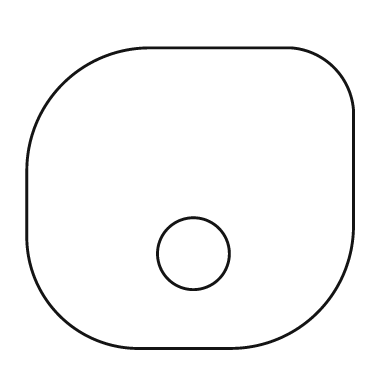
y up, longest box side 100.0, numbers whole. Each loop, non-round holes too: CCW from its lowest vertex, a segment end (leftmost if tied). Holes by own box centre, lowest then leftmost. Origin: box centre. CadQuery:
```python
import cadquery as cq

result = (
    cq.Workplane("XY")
    .moveTo(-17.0, -46.0)
    .lineTo(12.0, -46.0)
    .threePointArc((39.0, -35.0), (50.0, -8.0))
    .lineTo(50.0, 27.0)
    .threePointArc((44.0, 40.0), (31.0, 46.0))
    .lineTo(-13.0, 46.0)
    .threePointArc((-39.0, 35.0), (-50.0, 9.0))
    .lineTo(-50.0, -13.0)
    .threePointArc((-40.0, -36.0), (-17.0, -46.0))
    .close()
    .moveTo(1.0, -17.0)
    .circle(11.0)
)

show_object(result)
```